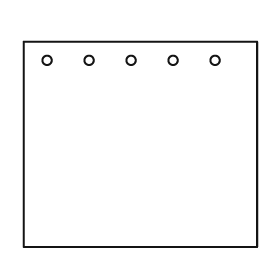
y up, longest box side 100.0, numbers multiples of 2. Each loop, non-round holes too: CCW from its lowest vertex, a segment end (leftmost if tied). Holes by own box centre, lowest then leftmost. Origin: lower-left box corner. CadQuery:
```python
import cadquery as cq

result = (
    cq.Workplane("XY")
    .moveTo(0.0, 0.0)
    .lineTo(100.0, 0.0)
    .lineTo(100.0, 88.0)
    .lineTo(0.0, 88.0)
    .close()
    .moveTo(10.0, 80.0)
    .circle(2.0)
    .moveTo(28.0, 80.0)
    .circle(2.0)
    .moveTo(46.0, 80.0)
    .circle(2.0)
    .moveTo(64.0, 80.0)
    .circle(2.0)
    .moveTo(82.0, 80.0)
    .circle(2.0)
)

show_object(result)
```